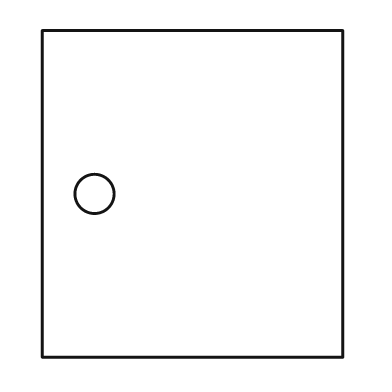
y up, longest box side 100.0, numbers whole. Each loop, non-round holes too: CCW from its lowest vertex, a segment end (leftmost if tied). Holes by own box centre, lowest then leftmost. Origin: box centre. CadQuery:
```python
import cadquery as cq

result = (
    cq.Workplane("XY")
    .moveTo(-46.0, -50.0)
    .lineTo(46.0, -50.0)
    .lineTo(46.0, 50.0)
    .lineTo(-46.0, 50.0)
    .close()
    .moveTo(-30.0, 0.0)
    .circle(6.0)
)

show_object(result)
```